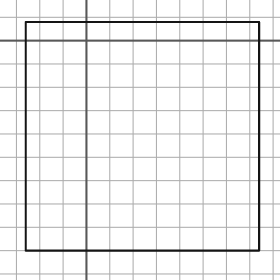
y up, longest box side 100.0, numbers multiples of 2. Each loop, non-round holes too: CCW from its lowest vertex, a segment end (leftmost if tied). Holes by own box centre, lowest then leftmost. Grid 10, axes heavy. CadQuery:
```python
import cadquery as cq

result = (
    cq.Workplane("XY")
    .moveTo(-26.0, -90.0)
    .lineTo(74.0, -90.0)
    .lineTo(74.0, 8.0)
    .lineTo(-26.0, 8.0)
    .close()
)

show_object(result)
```